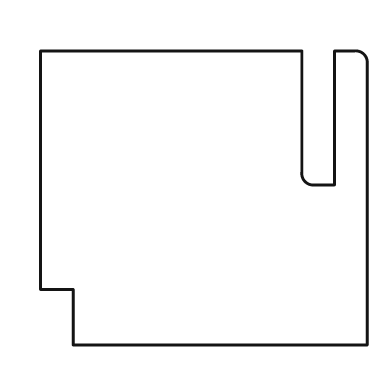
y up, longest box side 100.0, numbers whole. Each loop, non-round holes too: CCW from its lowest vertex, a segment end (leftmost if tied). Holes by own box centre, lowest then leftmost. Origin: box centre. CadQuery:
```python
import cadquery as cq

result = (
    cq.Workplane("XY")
    .moveTo(-40.0, -45.0)
    .lineTo(50.0, -45.0)
    .lineTo(50.0, 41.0)
    .threePointArc((49.0, 44.0), (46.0, 45.0))
    .lineTo(40.0, 45.0)
    .lineTo(40.0, 4.0)
    .lineTo(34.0, 4.0)
    .threePointArc((31.0, 5.0), (30.0, 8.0))
    .lineTo(30.0, 45.0)
    .lineTo(-50.0, 45.0)
    .lineTo(-50.0, -28.0)
    .lineTo(-40.0, -28.0)
    .close()
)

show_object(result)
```